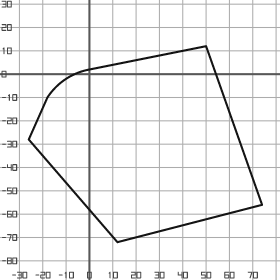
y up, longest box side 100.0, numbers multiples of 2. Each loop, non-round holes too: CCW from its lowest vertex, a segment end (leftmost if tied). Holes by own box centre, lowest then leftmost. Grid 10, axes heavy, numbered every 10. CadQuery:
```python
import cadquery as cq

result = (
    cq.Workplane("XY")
    .moveTo(12.0, -72.0)
    .lineTo(74.0, -56.0)
    .lineTo(50.0, 12.0)
    .lineTo(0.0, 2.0)
    .threePointArc((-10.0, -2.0), (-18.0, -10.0))
    .lineTo(-26.0, -28.0)
    .close()
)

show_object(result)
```